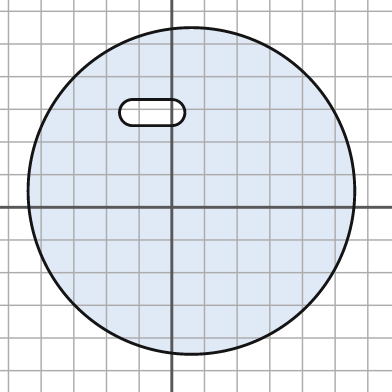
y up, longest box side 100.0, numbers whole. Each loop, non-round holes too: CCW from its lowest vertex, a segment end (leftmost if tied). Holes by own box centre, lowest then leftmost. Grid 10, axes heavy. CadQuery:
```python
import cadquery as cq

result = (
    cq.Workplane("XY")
    .moveTo(6.0, 5.0)
    .circle(50.0)
    .moveTo(-12.0, 25.0)
    .lineTo(0.0, 25.0)
    .threePointArc((4.0, 29.0), (0.0, 33.0))
    .lineTo(-12.0, 33.0)
    .threePointArc((-16.0, 29.0), (-12.0, 25.0))
    .close()
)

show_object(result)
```